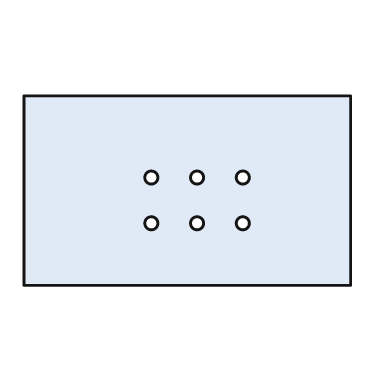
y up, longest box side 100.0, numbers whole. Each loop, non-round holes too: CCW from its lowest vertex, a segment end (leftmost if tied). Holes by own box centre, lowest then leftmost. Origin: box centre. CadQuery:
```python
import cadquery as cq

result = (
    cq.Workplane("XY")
    .moveTo(-50.0, -29.0)
    .lineTo(50.0, -29.0)
    .lineTo(50.0, 29.0)
    .lineTo(-50.0, 29.0)
    .close()
    .moveTo(-11.0, -10.0)
    .circle(2.0)
    .moveTo(3.0, -10.0)
    .circle(2.0)
    .moveTo(17.0, -10.0)
    .circle(2.0)
    .moveTo(-11.0, 4.0)
    .circle(2.0)
    .moveTo(3.0, 4.0)
    .circle(2.0)
    .moveTo(17.0, 4.0)
    .circle(2.0)
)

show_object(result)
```